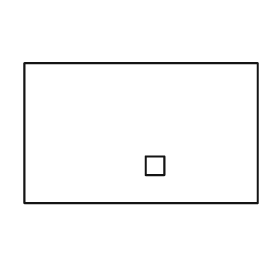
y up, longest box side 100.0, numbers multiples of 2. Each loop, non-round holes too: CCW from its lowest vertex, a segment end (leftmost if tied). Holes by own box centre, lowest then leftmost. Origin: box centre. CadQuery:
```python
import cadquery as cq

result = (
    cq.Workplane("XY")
    .moveTo(-50.0, -30.0)
    .lineTo(50.0, -30.0)
    .lineTo(50.0, 30.0)
    .lineTo(-50.0, 30.0)
    .close()
    .moveTo(2.0, -18.0)
    .lineTo(10.0, -18.0)
    .lineTo(10.0, -10.0)
    .lineTo(2.0, -10.0)
    .close()
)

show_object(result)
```